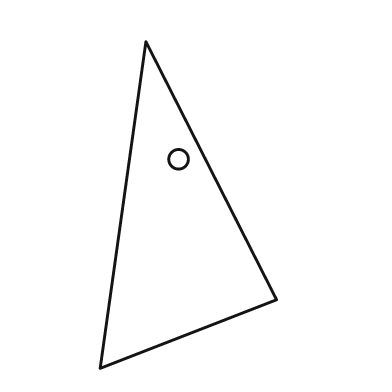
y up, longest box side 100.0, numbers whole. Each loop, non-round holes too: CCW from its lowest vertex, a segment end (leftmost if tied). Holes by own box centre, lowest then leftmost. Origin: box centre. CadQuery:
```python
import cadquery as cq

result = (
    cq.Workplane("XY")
    .moveTo(-27.0, -50.0)
    .lineTo(27.0, -29.0)
    .lineTo(-13.0, 50.0)
    .close()
    .moveTo(-3.0, 14.0)
    .circle(3.0)
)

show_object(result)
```